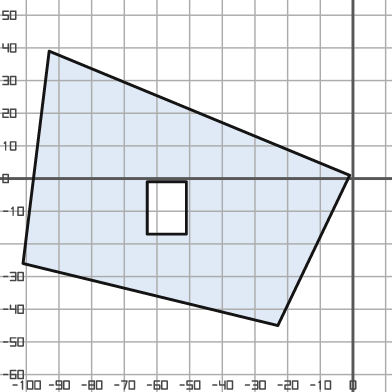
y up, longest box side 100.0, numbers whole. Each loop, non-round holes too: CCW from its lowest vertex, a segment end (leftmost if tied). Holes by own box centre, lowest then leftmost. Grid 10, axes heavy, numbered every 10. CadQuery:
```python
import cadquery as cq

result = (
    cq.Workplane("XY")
    .moveTo(-23.0, -45.0)
    .lineTo(-1.0, 1.0)
    .lineTo(-93.0, 39.0)
    .lineTo(-101.0, -26.0)
    .close()
    .moveTo(-63.0, -17.0)
    .lineTo(-51.0, -17.0)
    .lineTo(-51.0, -1.0)
    .lineTo(-63.0, -1.0)
    .close()
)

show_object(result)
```